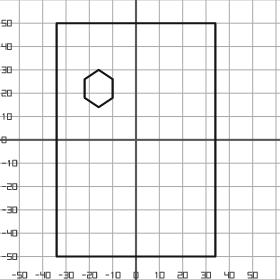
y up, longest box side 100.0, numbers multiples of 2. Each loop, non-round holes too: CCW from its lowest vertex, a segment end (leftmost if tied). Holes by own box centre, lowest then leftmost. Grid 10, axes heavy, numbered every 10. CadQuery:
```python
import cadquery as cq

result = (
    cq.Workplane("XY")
    .moveTo(-34.0, -50.0)
    .lineTo(34.0, -50.0)
    .lineTo(34.0, 50.0)
    .lineTo(-34.0, 50.0)
    .close()
    .moveTo(-16.0, 14.0)
    .lineTo(-10.0, 18.0)
    .lineTo(-10.0, 26.0)
    .lineTo(-16.0, 30.0)
    .lineTo(-22.0, 26.0)
    .lineTo(-22.0, 18.0)
    .close()
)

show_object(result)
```